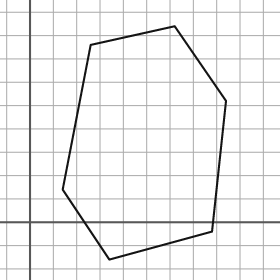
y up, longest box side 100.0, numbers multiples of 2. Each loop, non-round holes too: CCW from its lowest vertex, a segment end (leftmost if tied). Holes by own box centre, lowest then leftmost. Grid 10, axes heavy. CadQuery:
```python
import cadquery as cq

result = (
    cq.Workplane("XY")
    .moveTo(34.0, -16.0)
    .lineTo(78.0, -4.0)
    .lineTo(84.0, 52.0)
    .lineTo(62.0, 84.0)
    .lineTo(26.0, 76.0)
    .lineTo(14.0, 14.0)
    .close()
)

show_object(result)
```